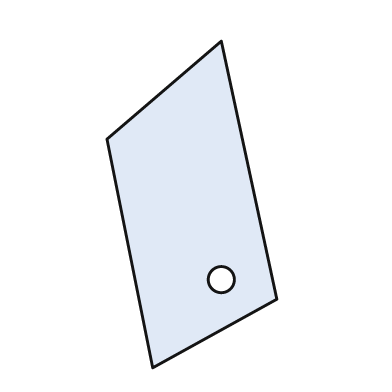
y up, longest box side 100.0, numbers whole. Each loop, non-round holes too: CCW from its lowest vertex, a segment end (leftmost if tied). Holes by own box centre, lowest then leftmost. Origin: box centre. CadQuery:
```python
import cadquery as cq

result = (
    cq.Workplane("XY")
    .moveTo(-12.0, -50.0)
    .lineTo(26.0, -29.0)
    .lineTo(9.0, 50.0)
    .lineTo(-26.0, 20.0)
    .close()
    .moveTo(9.0, -23.0)
    .circle(4.0)
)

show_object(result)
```